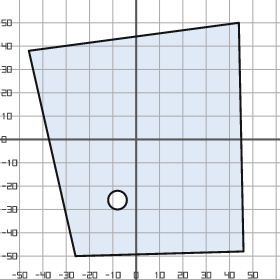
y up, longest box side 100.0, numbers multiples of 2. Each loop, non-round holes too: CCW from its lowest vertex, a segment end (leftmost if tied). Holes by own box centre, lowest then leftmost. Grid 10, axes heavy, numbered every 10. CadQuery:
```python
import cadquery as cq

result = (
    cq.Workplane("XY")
    .moveTo(-26.0, -50.0)
    .lineTo(46.0, -48.0)
    .lineTo(44.0, 50.0)
    .lineTo(-46.0, 38.0)
    .close()
    .moveTo(-8.0, -26.0)
    .circle(4.0)
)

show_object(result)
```